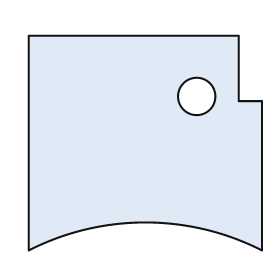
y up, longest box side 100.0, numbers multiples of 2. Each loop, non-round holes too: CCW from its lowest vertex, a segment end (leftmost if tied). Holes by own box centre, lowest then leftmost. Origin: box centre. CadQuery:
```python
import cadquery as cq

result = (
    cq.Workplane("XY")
    .moveTo(-50.0, -46.0)
    .threePointArc((0.0, -34.0), (50.0, -46.0))
    .lineTo(50.0, 18.0)
    .lineTo(40.0, 18.0)
    .lineTo(40.0, 46.0)
    .lineTo(-50.0, 46.0)
    .close()
    .moveTo(22.0, 20.0)
    .circle(8.0)
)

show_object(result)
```